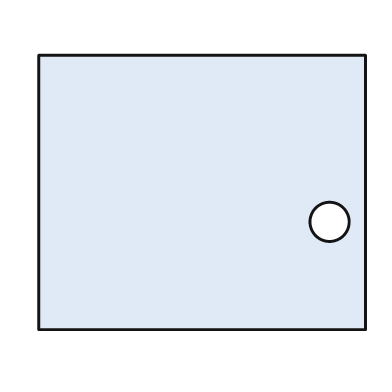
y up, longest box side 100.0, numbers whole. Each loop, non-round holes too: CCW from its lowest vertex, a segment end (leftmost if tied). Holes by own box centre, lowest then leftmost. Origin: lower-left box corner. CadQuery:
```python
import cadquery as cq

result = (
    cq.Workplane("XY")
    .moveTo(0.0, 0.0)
    .lineTo(100.0, 0.0)
    .lineTo(100.0, 84.0)
    .lineTo(0.0, 84.0)
    .close()
    .moveTo(89.0, 33.0)
    .circle(6.0)
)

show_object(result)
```